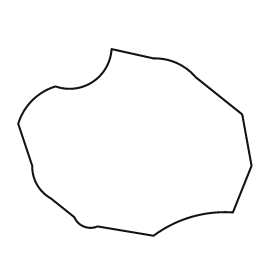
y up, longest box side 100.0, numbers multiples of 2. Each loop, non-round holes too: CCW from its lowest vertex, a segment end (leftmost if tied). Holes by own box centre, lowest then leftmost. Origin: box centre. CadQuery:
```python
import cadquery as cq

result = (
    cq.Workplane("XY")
    .moveTo(8.0, -40.0)
    .threePointArc((24.0, -32.0), (42.0, -30.0))
    .lineTo(50.0, -10.0)
    .lineTo(46.0, 12.0)
    .lineTo(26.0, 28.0)
    .threePointArc((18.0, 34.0), (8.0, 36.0))
    .lineTo(-10.0, 40.0)
    .threePointArc((-18.0, 26.0), (-34.0, 24.0))
    .threePointArc((-44.0, 18.0), (-50.0, 8.0))
    .lineTo(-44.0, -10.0)
    .threePointArc((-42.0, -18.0), (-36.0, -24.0))
    .lineTo(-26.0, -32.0)
    .threePointArc((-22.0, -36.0), (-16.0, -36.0))
    .close()
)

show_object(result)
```